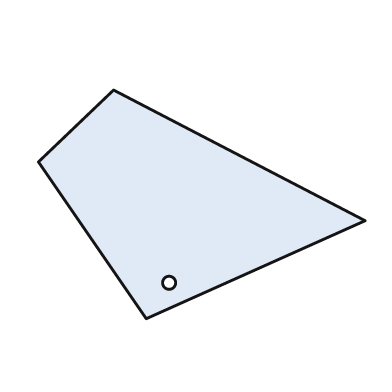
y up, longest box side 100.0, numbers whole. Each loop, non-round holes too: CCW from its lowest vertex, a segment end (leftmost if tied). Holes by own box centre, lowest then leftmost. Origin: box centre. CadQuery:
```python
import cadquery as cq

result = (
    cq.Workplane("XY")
    .moveTo(-17.0, -35.0)
    .lineTo(50.0, -5.0)
    .lineTo(-27.0, 35.0)
    .lineTo(-50.0, 13.0)
    .close()
    .moveTo(-10.0, -24.0)
    .circle(2.0)
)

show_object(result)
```